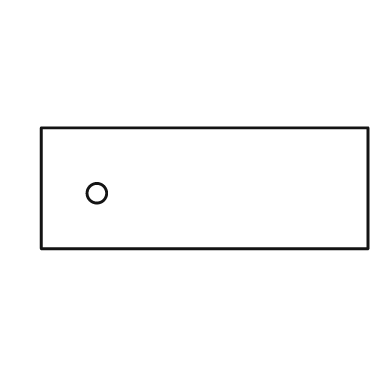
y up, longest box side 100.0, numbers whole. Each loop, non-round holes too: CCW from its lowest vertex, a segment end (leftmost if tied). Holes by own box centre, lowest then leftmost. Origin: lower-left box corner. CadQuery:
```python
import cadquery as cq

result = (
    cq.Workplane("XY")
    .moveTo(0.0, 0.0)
    .lineTo(100.0, 0.0)
    .lineTo(100.0, 37.0)
    .lineTo(0.0, 37.0)
    .close()
    .moveTo(17.0, 17.0)
    .circle(3.0)
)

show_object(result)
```